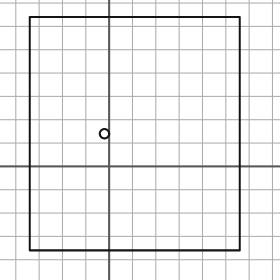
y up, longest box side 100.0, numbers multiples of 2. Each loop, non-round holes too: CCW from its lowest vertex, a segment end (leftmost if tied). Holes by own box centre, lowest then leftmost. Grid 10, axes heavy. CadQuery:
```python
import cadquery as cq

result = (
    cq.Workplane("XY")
    .moveTo(-34.0, -36.0)
    .lineTo(56.0, -36.0)
    .lineTo(56.0, 64.0)
    .lineTo(-34.0, 64.0)
    .close()
    .moveTo(-2.0, 14.0)
    .circle(2.0)
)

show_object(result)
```